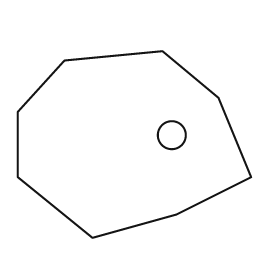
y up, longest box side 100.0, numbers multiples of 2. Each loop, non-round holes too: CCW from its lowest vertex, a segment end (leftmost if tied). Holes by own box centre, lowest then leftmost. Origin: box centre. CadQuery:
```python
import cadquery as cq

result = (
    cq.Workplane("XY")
    .moveTo(-18.0, -40.0)
    .lineTo(18.0, -30.0)
    .lineTo(50.0, -14.0)
    .lineTo(36.0, 20.0)
    .lineTo(12.0, 40.0)
    .lineTo(-30.0, 36.0)
    .lineTo(-50.0, 14.0)
    .lineTo(-50.0, -14.0)
    .close()
    .moveTo(16.0, 4.0)
    .circle(6.0)
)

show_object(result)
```